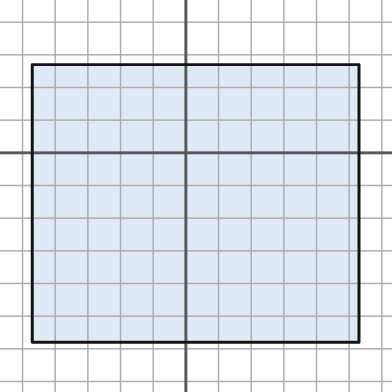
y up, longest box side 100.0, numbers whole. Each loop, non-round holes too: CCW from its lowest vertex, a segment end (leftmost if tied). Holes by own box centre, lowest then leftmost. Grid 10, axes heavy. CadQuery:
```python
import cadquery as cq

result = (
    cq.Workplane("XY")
    .moveTo(-47.0, -58.0)
    .lineTo(53.0, -58.0)
    .lineTo(53.0, 27.0)
    .lineTo(-47.0, 27.0)
    .close()
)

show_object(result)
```